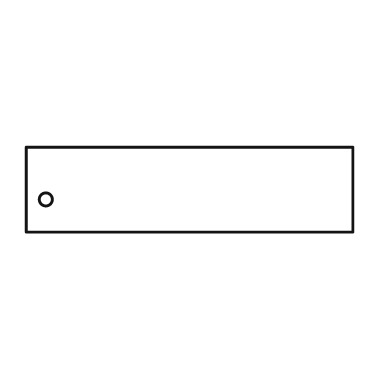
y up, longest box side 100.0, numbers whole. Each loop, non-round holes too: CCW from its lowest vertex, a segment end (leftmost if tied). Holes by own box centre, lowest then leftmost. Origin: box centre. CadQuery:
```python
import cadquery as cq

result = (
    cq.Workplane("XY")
    .moveTo(-50.0, -13.0)
    .lineTo(50.0, -13.0)
    .lineTo(50.0, 13.0)
    .lineTo(-50.0, 13.0)
    .close()
    .moveTo(-44.0, -3.0)
    .circle(2.0)
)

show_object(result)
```